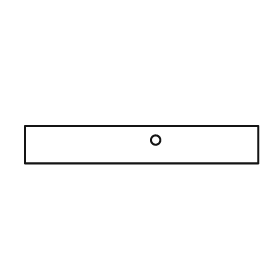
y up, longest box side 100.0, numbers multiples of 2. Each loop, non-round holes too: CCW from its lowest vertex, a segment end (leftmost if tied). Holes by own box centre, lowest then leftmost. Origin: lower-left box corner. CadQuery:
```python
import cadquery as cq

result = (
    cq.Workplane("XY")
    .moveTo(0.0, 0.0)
    .lineTo(100.0, 0.0)
    .lineTo(100.0, 16.0)
    .lineTo(0.0, 16.0)
    .close()
    .moveTo(56.0, 10.0)
    .circle(2.0)
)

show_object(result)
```